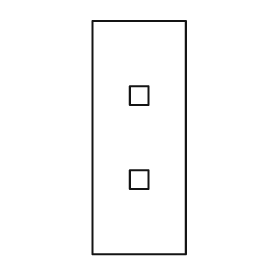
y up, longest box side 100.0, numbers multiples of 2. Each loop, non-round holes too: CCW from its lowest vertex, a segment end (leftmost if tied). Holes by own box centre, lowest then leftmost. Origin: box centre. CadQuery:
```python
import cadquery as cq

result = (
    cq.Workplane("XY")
    .moveTo(-20.0, -50.0)
    .lineTo(20.0, -50.0)
    .lineTo(20.0, 50.0)
    .lineTo(-20.0, 50.0)
    .close()
    .moveTo(-4.0, -22.0)
    .lineTo(4.0, -22.0)
    .lineTo(4.0, -14.0)
    .lineTo(-4.0, -14.0)
    .close()
    .moveTo(-4.0, 14.0)
    .lineTo(4.0, 14.0)
    .lineTo(4.0, 22.0)
    .lineTo(-4.0, 22.0)
    .close()
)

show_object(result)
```